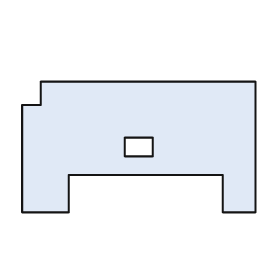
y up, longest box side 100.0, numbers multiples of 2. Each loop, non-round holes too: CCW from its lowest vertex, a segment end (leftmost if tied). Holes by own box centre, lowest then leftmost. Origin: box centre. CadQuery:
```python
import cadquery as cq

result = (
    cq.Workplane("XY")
    .moveTo(-50.0, -28.0)
    .lineTo(-30.0, -28.0)
    .lineTo(-30.0, -12.0)
    .lineTo(36.0, -12.0)
    .lineTo(36.0, -28.0)
    .lineTo(50.0, -28.0)
    .lineTo(50.0, 28.0)
    .lineTo(-42.0, 28.0)
    .lineTo(-42.0, 18.0)
    .lineTo(-50.0, 18.0)
    .close()
    .moveTo(-6.0, -4.0)
    .lineTo(6.0, -4.0)
    .lineTo(6.0, 4.0)
    .lineTo(-6.0, 4.0)
    .close()
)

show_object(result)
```